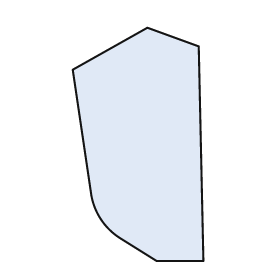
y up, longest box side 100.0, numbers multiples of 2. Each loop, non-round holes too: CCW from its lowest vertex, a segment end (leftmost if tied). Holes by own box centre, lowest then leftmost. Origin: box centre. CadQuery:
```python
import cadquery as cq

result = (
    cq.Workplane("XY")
    .moveTo(8.0, -50.0)
    .lineTo(28.0, -50.0)
    .lineTo(26.0, 42.0)
    .lineTo(4.0, 50.0)
    .lineTo(-28.0, 32.0)
    .lineTo(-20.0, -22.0)
    .threePointArc((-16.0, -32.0), (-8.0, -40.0))
    .close()
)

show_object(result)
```